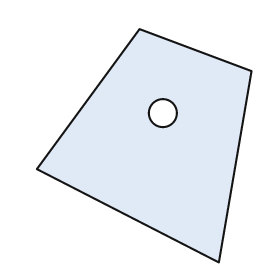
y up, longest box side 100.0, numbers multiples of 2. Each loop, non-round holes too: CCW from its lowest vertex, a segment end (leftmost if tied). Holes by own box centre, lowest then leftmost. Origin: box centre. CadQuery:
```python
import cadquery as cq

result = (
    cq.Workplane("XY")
    .moveTo(32.0, -50.0)
    .lineTo(46.0, 32.0)
    .lineTo(-2.0, 50.0)
    .lineTo(-46.0, -10.0)
    .close()
    .moveTo(8.0, 14.0)
    .circle(6.0)
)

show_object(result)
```